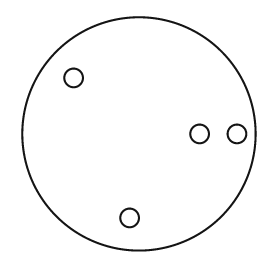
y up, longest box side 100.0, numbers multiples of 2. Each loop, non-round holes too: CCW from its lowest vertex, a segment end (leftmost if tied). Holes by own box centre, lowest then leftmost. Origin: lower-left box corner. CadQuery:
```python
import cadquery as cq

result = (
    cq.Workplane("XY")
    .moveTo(50.0, 50.0)
    .circle(50.0)
    .moveTo(46.0, 14.0)
    .circle(4.0)
    .moveTo(76.0, 50.0)
    .circle(4.0)
    .moveTo(92.0, 50.0)
    .circle(4.0)
    .moveTo(22.0, 74.0)
    .circle(4.0)
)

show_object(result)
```